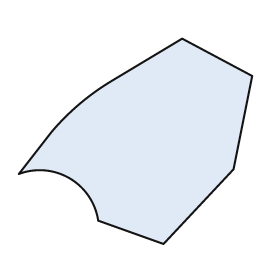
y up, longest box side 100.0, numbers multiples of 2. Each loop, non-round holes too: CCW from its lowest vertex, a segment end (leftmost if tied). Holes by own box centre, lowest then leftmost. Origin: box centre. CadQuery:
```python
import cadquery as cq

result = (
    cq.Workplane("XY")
    .moveTo(12.0, -44.0)
    .lineTo(42.0, -12.0)
    .lineTo(50.0, 28.0)
    .lineTo(20.0, 44.0)
    .lineTo(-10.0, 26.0)
    .threePointArc((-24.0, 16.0), (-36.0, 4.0))
    .lineTo(-50.0, -14.0)
    .threePointArc((-28.0, -16.0), (-16.0, -34.0))
    .close()
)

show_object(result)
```